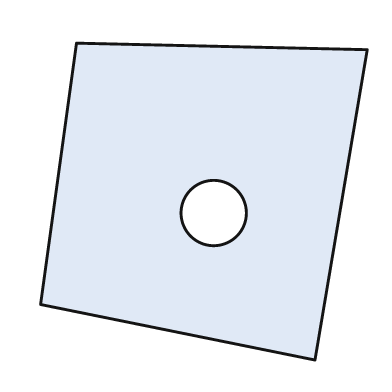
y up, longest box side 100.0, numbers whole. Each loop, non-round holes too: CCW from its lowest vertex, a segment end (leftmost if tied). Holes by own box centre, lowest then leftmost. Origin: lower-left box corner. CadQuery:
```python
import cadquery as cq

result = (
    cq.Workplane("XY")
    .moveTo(84.0, 0.0)
    .lineTo(100.0, 95.0)
    .lineTo(11.0, 97.0)
    .lineTo(0.0, 17.0)
    .close()
    .moveTo(53.0, 45.0)
    .circle(10.0)
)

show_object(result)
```